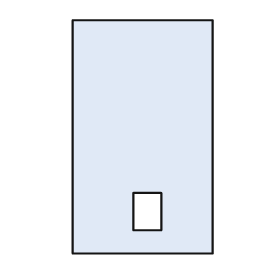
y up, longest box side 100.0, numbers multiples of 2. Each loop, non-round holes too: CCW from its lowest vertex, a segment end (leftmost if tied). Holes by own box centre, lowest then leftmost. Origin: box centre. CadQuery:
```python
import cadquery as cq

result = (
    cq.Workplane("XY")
    .moveTo(-30.0, -50.0)
    .lineTo(30.0, -50.0)
    .lineTo(30.0, 50.0)
    .lineTo(-30.0, 50.0)
    .close()
    .moveTo(-4.0, -40.0)
    .lineTo(8.0, -40.0)
    .lineTo(8.0, -24.0)
    .lineTo(-4.0, -24.0)
    .close()
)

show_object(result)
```